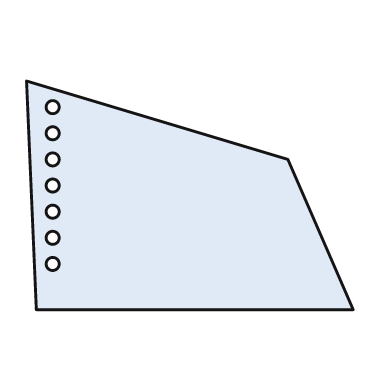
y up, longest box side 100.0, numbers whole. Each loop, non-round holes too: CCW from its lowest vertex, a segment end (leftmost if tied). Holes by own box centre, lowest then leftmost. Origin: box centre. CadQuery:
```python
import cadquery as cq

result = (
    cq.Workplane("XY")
    .moveTo(-47.0, -35.0)
    .lineTo(50.0, -35.0)
    .lineTo(30.0, 11.0)
    .lineTo(-50.0, 35.0)
    .close()
    .moveTo(-42.0, -21.0)
    .circle(2.0)
    .moveTo(-42.0, -13.0)
    .circle(2.0)
    .moveTo(-42.0, -5.0)
    .circle(2.0)
    .moveTo(-42.0, 3.0)
    .circle(2.0)
    .moveTo(-42.0, 11.0)
    .circle(2.0)
    .moveTo(-42.0, 19.0)
    .circle(2.0)
    .moveTo(-42.0, 27.0)
    .circle(2.0)
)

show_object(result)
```